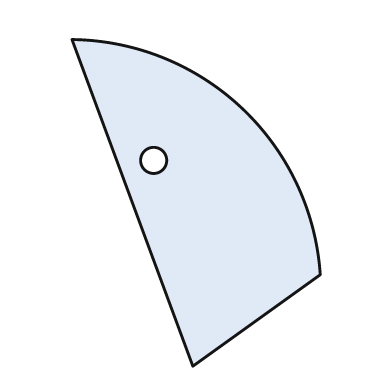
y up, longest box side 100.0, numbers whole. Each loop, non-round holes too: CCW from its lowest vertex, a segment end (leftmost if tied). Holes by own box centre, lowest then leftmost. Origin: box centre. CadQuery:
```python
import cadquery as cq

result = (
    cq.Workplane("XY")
    .moveTo(-1.0, -50.0)
    .lineTo(38.0, -22.0)
    .threePointArc((14.0, 29.0), (-38.0, 50.0))
    .close()
    .moveTo(-13.0, 13.0)
    .circle(4.0)
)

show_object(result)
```